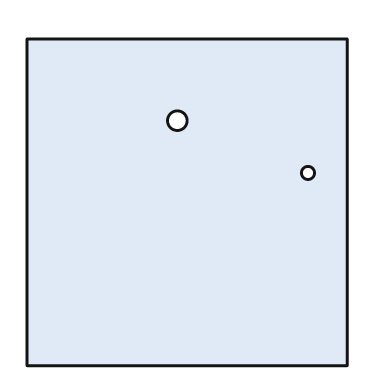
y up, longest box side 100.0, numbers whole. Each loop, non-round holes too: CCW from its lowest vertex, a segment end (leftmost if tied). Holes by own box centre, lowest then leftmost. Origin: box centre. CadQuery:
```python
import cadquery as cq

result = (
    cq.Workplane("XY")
    .moveTo(-49.0, -50.0)
    .lineTo(49.0, -50.0)
    .lineTo(49.0, 50.0)
    .lineTo(-49.0, 50.0)
    .close()
    .moveTo(37.0, 9.0)
    .circle(2.0)
    .moveTo(-3.0, 25.0)
    .circle(3.0)
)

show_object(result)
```